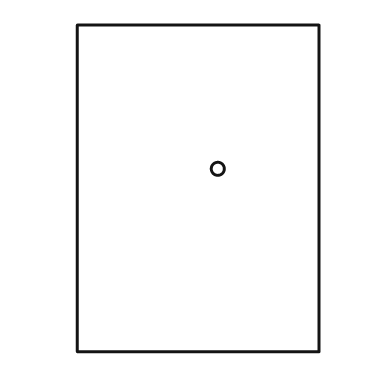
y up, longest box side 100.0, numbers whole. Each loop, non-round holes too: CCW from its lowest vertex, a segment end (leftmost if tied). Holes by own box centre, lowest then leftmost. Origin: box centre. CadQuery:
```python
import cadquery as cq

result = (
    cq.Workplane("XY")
    .moveTo(-37.0, -50.0)
    .lineTo(37.0, -50.0)
    .lineTo(37.0, 50.0)
    .lineTo(-37.0, 50.0)
    .close()
    .moveTo(6.0, 6.0)
    .circle(2.0)
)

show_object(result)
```